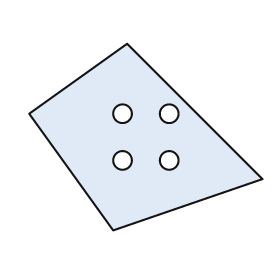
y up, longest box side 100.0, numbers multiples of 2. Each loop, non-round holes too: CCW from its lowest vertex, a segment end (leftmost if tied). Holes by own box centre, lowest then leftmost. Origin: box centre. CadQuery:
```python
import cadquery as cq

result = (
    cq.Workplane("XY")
    .moveTo(-14.0, -40.0)
    .lineTo(50.0, -18.0)
    .lineTo(-8.0, 40.0)
    .lineTo(-50.0, 10.0)
    .close()
    .moveTo(-10.0, -10.0)
    .circle(4.0)
    .moveTo(10.0, -10.0)
    .circle(4.0)
    .moveTo(-10.0, 10.0)
    .circle(4.0)
    .moveTo(10.0, 10.0)
    .circle(4.0)
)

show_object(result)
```